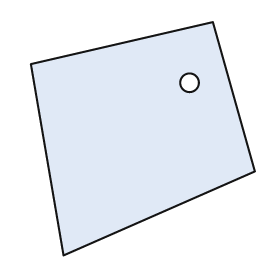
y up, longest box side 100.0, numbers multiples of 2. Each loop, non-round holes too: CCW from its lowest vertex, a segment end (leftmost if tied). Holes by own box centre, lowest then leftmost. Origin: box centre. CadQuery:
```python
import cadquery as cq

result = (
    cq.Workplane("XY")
    .moveTo(-34.0, -50.0)
    .lineTo(48.0, -14.0)
    .lineTo(30.0, 50.0)
    .lineTo(-48.0, 32.0)
    .close()
    .moveTo(20.0, 24.0)
    .circle(4.0)
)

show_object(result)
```